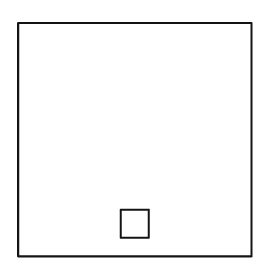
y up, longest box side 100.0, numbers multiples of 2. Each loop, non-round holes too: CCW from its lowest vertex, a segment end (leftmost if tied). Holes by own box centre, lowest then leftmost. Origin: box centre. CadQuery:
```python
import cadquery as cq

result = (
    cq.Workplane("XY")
    .moveTo(-50.0, -50.0)
    .lineTo(50.0, -50.0)
    .lineTo(50.0, 50.0)
    .lineTo(-50.0, 50.0)
    .close()
    .moveTo(-6.0, -42.0)
    .lineTo(6.0, -42.0)
    .lineTo(6.0, -30.0)
    .lineTo(-6.0, -30.0)
    .close()
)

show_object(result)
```